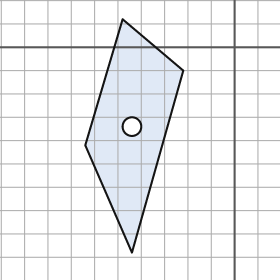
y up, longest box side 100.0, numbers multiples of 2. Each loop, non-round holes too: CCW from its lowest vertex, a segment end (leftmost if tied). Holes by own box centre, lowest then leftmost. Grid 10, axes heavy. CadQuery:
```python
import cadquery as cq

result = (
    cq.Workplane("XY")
    .moveTo(-44.0, -88.0)
    .lineTo(-22.0, -10.0)
    .lineTo(-48.0, 12.0)
    .lineTo(-64.0, -42.0)
    .close()
    .moveTo(-44.0, -34.0)
    .circle(4.0)
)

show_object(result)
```